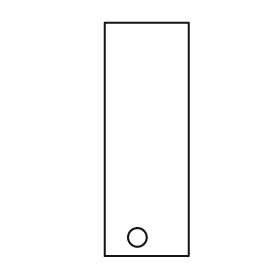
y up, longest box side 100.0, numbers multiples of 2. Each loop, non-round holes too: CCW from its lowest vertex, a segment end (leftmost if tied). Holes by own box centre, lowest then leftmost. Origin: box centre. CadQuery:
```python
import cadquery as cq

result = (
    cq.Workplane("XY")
    .moveTo(-18.0, -50.0)
    .lineTo(18.0, -50.0)
    .lineTo(18.0, 50.0)
    .lineTo(-18.0, 50.0)
    .close()
    .moveTo(-4.0, -42.0)
    .circle(4.0)
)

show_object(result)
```